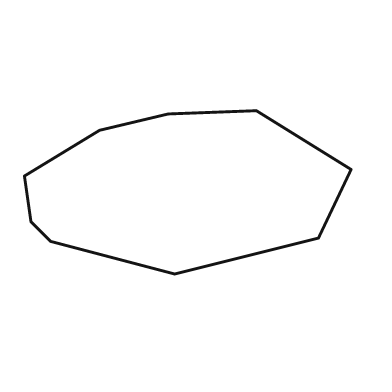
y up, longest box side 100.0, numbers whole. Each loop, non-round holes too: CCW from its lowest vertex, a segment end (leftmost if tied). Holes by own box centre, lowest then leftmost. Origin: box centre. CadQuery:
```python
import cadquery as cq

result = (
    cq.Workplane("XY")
    .moveTo(-4.0, -25.0)
    .lineTo(40.0, -14.0)
    .lineTo(50.0, 7.0)
    .lineTo(21.0, 25.0)
    .lineTo(-6.0, 24.0)
    .lineTo(-27.0, 19.0)
    .lineTo(-50.0, 5.0)
    .lineTo(-48.0, -9.0)
    .lineTo(-42.0, -15.0)
    .close()
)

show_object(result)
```